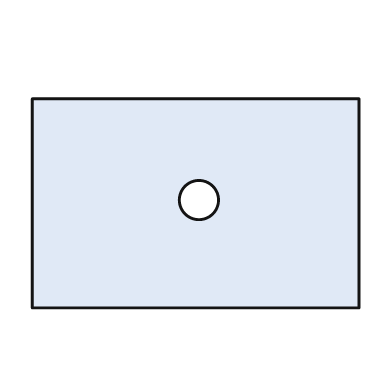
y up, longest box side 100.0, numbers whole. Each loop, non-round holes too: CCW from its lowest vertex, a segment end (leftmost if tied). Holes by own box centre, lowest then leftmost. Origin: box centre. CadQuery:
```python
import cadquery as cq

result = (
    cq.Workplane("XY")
    .moveTo(-50.0, -32.0)
    .lineTo(50.0, -32.0)
    .lineTo(50.0, 32.0)
    .lineTo(-50.0, 32.0)
    .close()
    .moveTo(1.0, 1.0)
    .circle(6.0)
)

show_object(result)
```